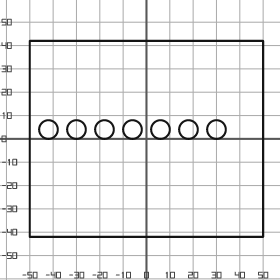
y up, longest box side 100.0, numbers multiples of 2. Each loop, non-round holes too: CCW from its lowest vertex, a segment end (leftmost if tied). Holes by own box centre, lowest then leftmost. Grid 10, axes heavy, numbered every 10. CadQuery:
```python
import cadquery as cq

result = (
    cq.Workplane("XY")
    .moveTo(-50.0, -42.0)
    .lineTo(50.0, -42.0)
    .lineTo(50.0, 42.0)
    .lineTo(-50.0, 42.0)
    .close()
    .moveTo(-42.0, 4.0)
    .circle(4.0)
    .moveTo(-30.0, 4.0)
    .circle(4.0)
    .moveTo(-18.0, 4.0)
    .circle(4.0)
    .moveTo(-6.0, 4.0)
    .circle(4.0)
    .moveTo(6.0, 4.0)
    .circle(4.0)
    .moveTo(18.0, 4.0)
    .circle(4.0)
    .moveTo(30.0, 4.0)
    .circle(4.0)
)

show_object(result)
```